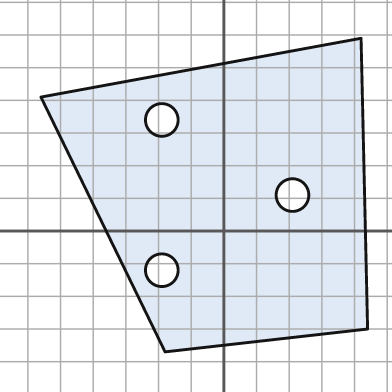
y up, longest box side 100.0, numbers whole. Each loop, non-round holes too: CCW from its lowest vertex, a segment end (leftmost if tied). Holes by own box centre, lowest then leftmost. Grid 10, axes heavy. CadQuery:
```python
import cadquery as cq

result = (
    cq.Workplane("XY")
    .moveTo(-18.0, -37.0)
    .lineTo(44.0, -30.0)
    .lineTo(42.0, 59.0)
    .lineTo(-56.0, 41.0)
    .close()
    .moveTo(-19.0, -12.0)
    .circle(5.0)
    .moveTo(21.0, 11.0)
    .circle(5.0)
    .moveTo(-19.0, 34.0)
    .circle(5.0)
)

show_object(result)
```